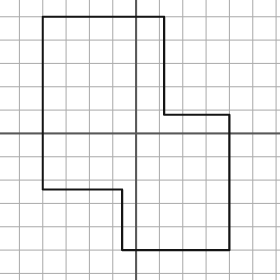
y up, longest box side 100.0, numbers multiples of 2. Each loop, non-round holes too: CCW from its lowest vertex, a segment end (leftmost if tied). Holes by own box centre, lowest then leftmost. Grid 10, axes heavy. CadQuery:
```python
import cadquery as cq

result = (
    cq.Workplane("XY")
    .moveTo(-6.0, -50.0)
    .lineTo(40.0, -50.0)
    .lineTo(40.0, 8.0)
    .lineTo(12.0, 8.0)
    .lineTo(12.0, 50.0)
    .lineTo(-40.0, 50.0)
    .lineTo(-40.0, -24.0)
    .lineTo(-6.0, -24.0)
    .close()
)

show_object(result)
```